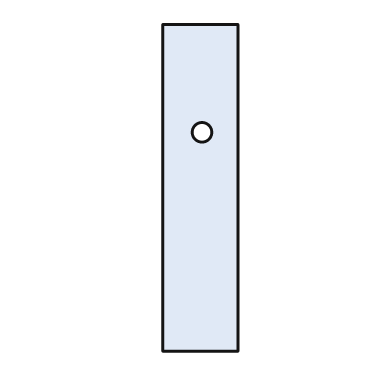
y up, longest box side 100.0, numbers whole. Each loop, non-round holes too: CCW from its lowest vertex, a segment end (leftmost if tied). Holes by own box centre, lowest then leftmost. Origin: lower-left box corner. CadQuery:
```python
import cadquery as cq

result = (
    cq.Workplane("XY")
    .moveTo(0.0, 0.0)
    .lineTo(23.0, 0.0)
    .lineTo(23.0, 100.0)
    .lineTo(0.0, 100.0)
    .close()
    .moveTo(12.0, 67.0)
    .circle(3.0)
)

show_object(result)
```